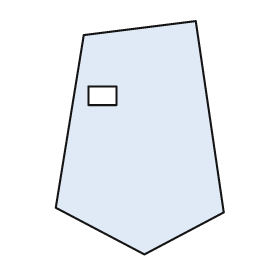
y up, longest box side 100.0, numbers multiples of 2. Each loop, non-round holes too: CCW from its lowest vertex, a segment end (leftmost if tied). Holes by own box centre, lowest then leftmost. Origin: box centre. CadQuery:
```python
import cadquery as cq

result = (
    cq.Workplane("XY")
    .moveTo(2.0, -50.0)
    .lineTo(36.0, -32.0)
    .lineTo(24.0, 50.0)
    .lineTo(-24.0, 44.0)
    .lineTo(-36.0, -30.0)
    .close()
    .moveTo(-22.0, 14.0)
    .lineTo(-10.0, 14.0)
    .lineTo(-10.0, 22.0)
    .lineTo(-22.0, 22.0)
    .close()
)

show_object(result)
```